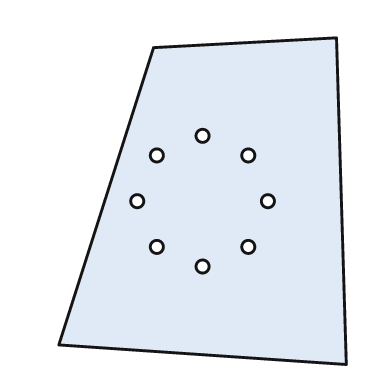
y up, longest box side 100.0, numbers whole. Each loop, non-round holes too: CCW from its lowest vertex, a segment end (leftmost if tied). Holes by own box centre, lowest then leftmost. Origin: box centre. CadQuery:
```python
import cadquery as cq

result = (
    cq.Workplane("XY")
    .moveTo(44.0, -50.0)
    .lineTo(41.0, 50.0)
    .lineTo(-15.0, 47.0)
    .lineTo(-44.0, -44.0)
    .close()
    .moveTo(0.0, -20.0)
    .circle(2.0)
    .moveTo(-14.0, -14.0)
    .circle(2.0)
    .moveTo(14.0, -14.0)
    .circle(2.0)
    .moveTo(-20.0, 0.0)
    .circle(2.0)
    .moveTo(20.0, 0.0)
    .circle(2.0)
    .moveTo(-14.0, 14.0)
    .circle(2.0)
    .moveTo(14.0, 14.0)
    .circle(2.0)
    .moveTo(0.0, 20.0)
    .circle(2.0)
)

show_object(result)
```